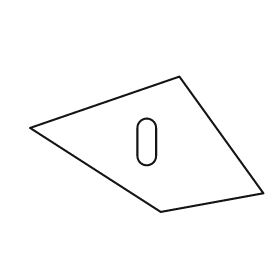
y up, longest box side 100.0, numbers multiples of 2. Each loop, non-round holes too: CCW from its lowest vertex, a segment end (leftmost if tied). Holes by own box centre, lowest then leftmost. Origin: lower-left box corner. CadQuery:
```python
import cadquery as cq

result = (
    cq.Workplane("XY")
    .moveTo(56.0, 0.0)
    .lineTo(100.0, 8.0)
    .lineTo(64.0, 58.0)
    .lineTo(0.0, 36.0)
    .close()
    .moveTo(46.0, 24.0)
    .threePointArc((50.0, 20.0), (54.0, 24.0))
    .lineTo(54.0, 36.0)
    .threePointArc((50.0, 40.0), (46.0, 36.0))
    .close()
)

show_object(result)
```